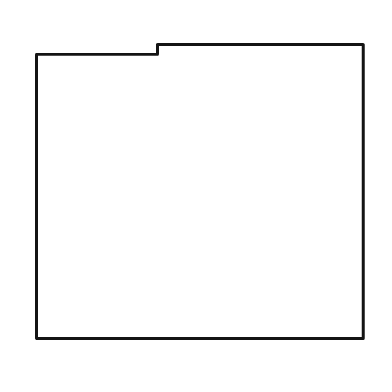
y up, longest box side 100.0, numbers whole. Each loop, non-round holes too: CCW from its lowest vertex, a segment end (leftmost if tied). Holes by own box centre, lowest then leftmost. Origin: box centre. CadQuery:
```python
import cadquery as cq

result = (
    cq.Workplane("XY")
    .moveTo(-50.0, -45.0)
    .lineTo(50.0, -45.0)
    .lineTo(50.0, 45.0)
    .lineTo(-13.0, 45.0)
    .lineTo(-13.0, 42.0)
    .lineTo(-50.0, 42.0)
    .close()
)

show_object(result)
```